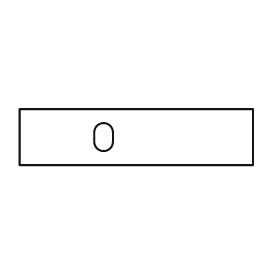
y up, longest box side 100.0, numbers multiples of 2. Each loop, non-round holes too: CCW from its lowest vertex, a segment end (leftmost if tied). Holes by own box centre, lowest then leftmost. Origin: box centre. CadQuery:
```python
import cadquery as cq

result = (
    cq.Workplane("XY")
    .moveTo(-50.0, -12.0)
    .lineTo(50.0, -12.0)
    .lineTo(50.0, 12.0)
    .lineTo(-50.0, 12.0)
    .close()
    .moveTo(-18.0, -2.0)
    .threePointArc((-14.0, -6.0), (-10.0, -2.0))
    .lineTo(-10.0, 2.0)
    .threePointArc((-14.0, 6.0), (-18.0, 2.0))
    .close()
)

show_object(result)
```